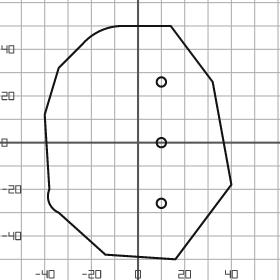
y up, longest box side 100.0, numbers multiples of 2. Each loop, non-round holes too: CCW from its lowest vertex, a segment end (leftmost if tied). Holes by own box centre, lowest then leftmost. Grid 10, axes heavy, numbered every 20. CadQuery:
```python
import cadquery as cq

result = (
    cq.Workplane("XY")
    .moveTo(16.0, -50.0)
    .lineTo(40.0, -18.0)
    .lineTo(32.0, 26.0)
    .lineTo(14.0, 50.0)
    .lineTo(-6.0, 50.0)
    .threePointArc((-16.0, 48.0), (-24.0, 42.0))
    .lineTo(-34.0, 32.0)
    .lineTo(-40.0, 12.0)
    .lineTo(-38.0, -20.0)
    .threePointArc((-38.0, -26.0), (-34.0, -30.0))
    .lineTo(-14.0, -48.0)
    .close()
    .moveTo(10.0, -26.0)
    .circle(2.0)
    .moveTo(10.0, 0.0)
    .circle(2.0)
    .moveTo(10.0, 26.0)
    .circle(2.0)
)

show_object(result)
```